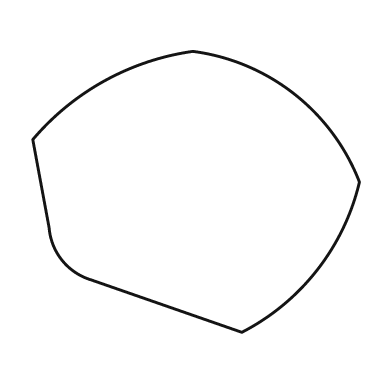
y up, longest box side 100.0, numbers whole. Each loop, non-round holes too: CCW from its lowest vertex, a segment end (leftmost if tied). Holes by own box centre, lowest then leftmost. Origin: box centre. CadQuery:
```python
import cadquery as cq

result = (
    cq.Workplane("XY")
    .moveTo(14.0, -43.0)
    .threePointArc((37.0, -24.0), (50.0, 3.0))
    .threePointArc((30.0, 30.0), (-1.0, 43.0))
    .threePointArc((-28.0, 34.0), (-50.0, 16.0))
    .lineTo(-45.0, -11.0)
    .threePointArc((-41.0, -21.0), (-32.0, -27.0))
    .close()
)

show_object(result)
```